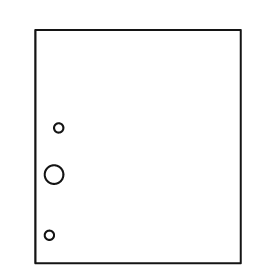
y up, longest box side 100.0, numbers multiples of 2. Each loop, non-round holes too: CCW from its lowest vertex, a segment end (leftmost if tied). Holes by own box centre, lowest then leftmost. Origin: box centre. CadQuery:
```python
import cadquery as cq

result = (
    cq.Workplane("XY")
    .moveTo(-44.0, -50.0)
    .lineTo(44.0, -50.0)
    .lineTo(44.0, 50.0)
    .lineTo(-44.0, 50.0)
    .close()
    .moveTo(-38.0, -38.0)
    .circle(2.0)
    .moveTo(-36.0, -12.0)
    .circle(4.0)
    .moveTo(-34.0, 8.0)
    .circle(2.0)
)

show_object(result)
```